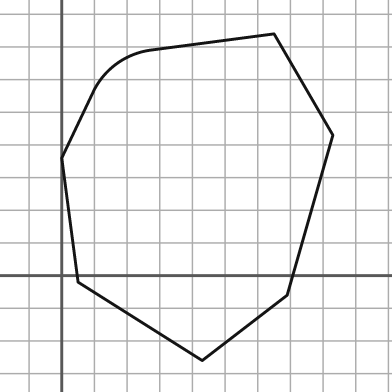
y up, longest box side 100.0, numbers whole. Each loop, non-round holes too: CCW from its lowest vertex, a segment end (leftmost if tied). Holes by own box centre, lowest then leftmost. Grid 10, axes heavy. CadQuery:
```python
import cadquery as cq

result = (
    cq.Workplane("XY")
    .moveTo(43.0, -26.0)
    .lineTo(69.0, -6.0)
    .lineTo(83.0, 43.0)
    .lineTo(65.0, 74.0)
    .lineTo(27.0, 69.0)
    .threePointArc((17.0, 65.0), (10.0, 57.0))
    .lineTo(0.0, 36.0)
    .lineTo(5.0, -2.0)
    .close()
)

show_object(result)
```